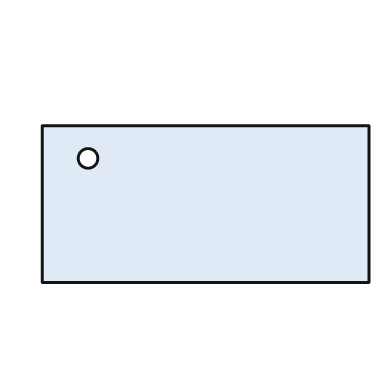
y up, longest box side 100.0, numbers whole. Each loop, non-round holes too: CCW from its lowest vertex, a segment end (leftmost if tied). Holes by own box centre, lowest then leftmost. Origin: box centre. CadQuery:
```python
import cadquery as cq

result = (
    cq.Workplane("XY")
    .moveTo(-50.0, -24.0)
    .lineTo(50.0, -24.0)
    .lineTo(50.0, 24.0)
    .lineTo(-50.0, 24.0)
    .close()
    .moveTo(-36.0, 14.0)
    .circle(3.0)
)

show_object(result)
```